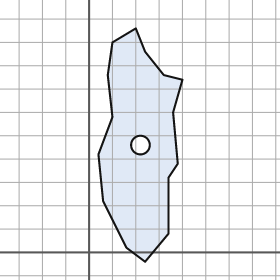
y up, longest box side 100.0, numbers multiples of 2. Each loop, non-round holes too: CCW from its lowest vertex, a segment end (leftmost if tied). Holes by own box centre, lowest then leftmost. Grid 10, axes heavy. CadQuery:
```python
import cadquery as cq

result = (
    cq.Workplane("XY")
    .moveTo(24.0, -4.0)
    .lineTo(34.0, 8.0)
    .lineTo(34.0, 32.0)
    .lineTo(38.0, 38.0)
    .lineTo(36.0, 60.0)
    .lineTo(40.0, 74.0)
    .lineTo(32.0, 76.0)
    .lineTo(24.0, 86.0)
    .lineTo(20.0, 96.0)
    .lineTo(10.0, 90.0)
    .lineTo(8.0, 76.0)
    .lineTo(10.0, 58.0)
    .lineTo(4.0, 42.0)
    .lineTo(6.0, 22.0)
    .lineTo(16.0, 2.0)
    .close()
    .moveTo(22.0, 46.0)
    .circle(4.0)
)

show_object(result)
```